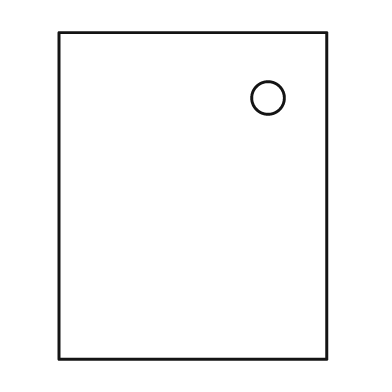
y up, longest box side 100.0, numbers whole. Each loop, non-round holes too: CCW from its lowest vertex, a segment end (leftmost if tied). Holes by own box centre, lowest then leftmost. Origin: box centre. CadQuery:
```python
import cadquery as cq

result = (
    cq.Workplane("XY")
    .moveTo(-41.0, -50.0)
    .lineTo(41.0, -50.0)
    .lineTo(41.0, 50.0)
    .lineTo(-41.0, 50.0)
    .close()
    .moveTo(23.0, 30.0)
    .circle(5.0)
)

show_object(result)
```